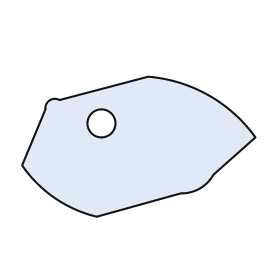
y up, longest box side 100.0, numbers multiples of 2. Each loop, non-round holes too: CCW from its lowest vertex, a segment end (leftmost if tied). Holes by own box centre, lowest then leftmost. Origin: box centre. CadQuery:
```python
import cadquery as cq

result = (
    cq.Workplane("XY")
    .moveTo(-18.0, -30.0)
    .lineTo(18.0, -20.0)
    .threePointArc((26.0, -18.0), (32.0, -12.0))
    .lineTo(50.0, 4.0)
    .threePointArc((30.0, 22.0), (4.0, 30.0))
    .lineTo(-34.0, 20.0)
    .threePointArc((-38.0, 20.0), (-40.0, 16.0))
    .lineTo(-50.0, -8.0)
    .threePointArc((-36.0, -22.0), (-18.0, -30.0))
    .close()
    .moveTo(-16.0, 10.0)
    .circle(6.0)
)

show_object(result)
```